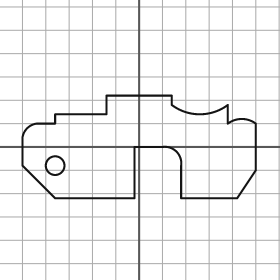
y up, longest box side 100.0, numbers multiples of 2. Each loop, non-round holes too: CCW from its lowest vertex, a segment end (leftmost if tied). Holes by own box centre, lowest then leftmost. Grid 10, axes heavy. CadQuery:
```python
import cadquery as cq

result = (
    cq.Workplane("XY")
    .moveTo(-36.0, -22.0)
    .lineTo(-2.0, -22.0)
    .lineTo(-2.0, 0.0)
    .lineTo(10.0, 0.0)
    .threePointArc((16.0, -2.0), (18.0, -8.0))
    .lineTo(18.0, -22.0)
    .lineTo(42.0, -22.0)
    .lineTo(50.0, -10.0)
    .lineTo(50.0, 10.0)
    .threePointArc((44.0, 12.0), (38.0, 10.0))
    .lineTo(38.0, 18.0)
    .threePointArc((26.0, 14.0), (14.0, 18.0))
    .lineTo(14.0, 22.0)
    .lineTo(-14.0, 22.0)
    .lineTo(-14.0, 14.0)
    .lineTo(-36.0, 14.0)
    .lineTo(-36.0, 10.0)
    .lineTo(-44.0, 10.0)
    .threePointArc((-48.0, 8.0), (-50.0, 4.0))
    .lineTo(-50.0, -8.0)
    .close()
    .moveTo(-36.0, -8.0)
    .circle(4.0)
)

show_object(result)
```